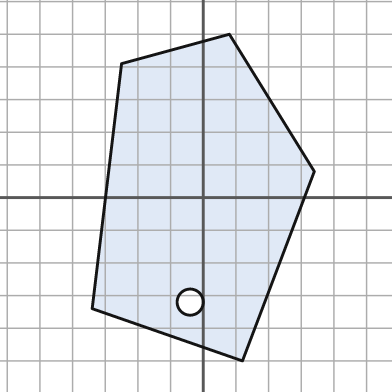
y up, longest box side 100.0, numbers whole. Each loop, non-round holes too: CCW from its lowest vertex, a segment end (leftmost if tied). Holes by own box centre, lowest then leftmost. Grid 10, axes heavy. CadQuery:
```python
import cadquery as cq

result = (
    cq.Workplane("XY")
    .moveTo(12.0, -50.0)
    .lineTo(34.0, 8.0)
    .lineTo(8.0, 50.0)
    .lineTo(-25.0, 41.0)
    .lineTo(-34.0, -34.0)
    .close()
    .moveTo(-4.0, -32.0)
    .circle(4.0)
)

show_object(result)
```